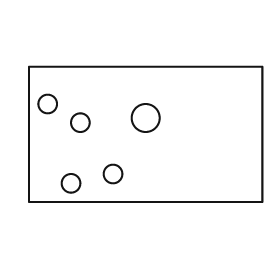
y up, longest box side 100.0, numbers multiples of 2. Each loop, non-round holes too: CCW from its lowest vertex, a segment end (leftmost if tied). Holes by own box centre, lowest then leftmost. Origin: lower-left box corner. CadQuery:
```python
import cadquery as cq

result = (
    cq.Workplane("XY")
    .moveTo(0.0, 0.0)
    .lineTo(100.0, 0.0)
    .lineTo(100.0, 58.0)
    .lineTo(0.0, 58.0)
    .close()
    .moveTo(18.0, 8.0)
    .circle(4.0)
    .moveTo(36.0, 12.0)
    .circle(4.0)
    .moveTo(22.0, 34.0)
    .circle(4.0)
    .moveTo(50.0, 36.0)
    .circle(6.0)
    .moveTo(8.0, 42.0)
    .circle(4.0)
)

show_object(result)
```